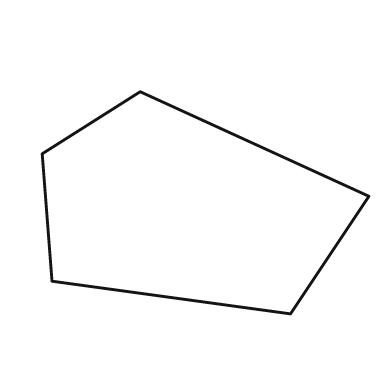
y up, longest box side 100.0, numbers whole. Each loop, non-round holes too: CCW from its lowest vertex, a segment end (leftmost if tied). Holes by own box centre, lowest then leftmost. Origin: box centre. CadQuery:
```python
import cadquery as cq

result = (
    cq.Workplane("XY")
    .moveTo(26.0, -34.0)
    .lineTo(50.0, 2.0)
    .lineTo(-20.0, 34.0)
    .lineTo(-50.0, 15.0)
    .lineTo(-47.0, -24.0)
    .close()
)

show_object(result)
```